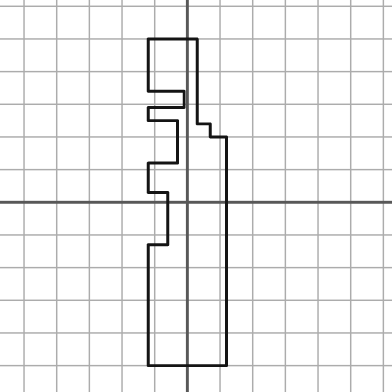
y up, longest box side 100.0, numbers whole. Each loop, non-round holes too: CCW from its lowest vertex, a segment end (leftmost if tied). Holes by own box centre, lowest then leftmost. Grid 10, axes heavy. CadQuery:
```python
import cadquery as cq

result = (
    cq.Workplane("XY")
    .moveTo(-12.0, -50.0)
    .lineTo(12.0, -50.0)
    .lineTo(12.0, 20.0)
    .lineTo(7.0, 20.0)
    .lineTo(7.0, 24.0)
    .lineTo(3.0, 24.0)
    .lineTo(3.0, 50.0)
    .lineTo(-12.0, 50.0)
    .lineTo(-12.0, 34.0)
    .lineTo(-1.0, 34.0)
    .lineTo(-1.0, 29.0)
    .lineTo(-12.0, 29.0)
    .lineTo(-12.0, 25.0)
    .lineTo(-3.0, 25.0)
    .lineTo(-3.0, 12.0)
    .lineTo(-12.0, 12.0)
    .lineTo(-12.0, 3.0)
    .lineTo(-6.0, 3.0)
    .lineTo(-6.0, -13.0)
    .lineTo(-12.0, -13.0)
    .close()
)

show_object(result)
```